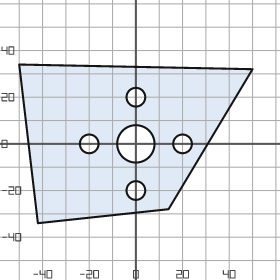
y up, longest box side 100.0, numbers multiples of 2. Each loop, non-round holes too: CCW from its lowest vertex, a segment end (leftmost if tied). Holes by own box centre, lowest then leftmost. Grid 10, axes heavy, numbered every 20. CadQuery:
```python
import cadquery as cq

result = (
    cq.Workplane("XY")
    .moveTo(-42.0, -34.0)
    .lineTo(14.0, -28.0)
    .lineTo(50.0, 32.0)
    .lineTo(-50.0, 34.0)
    .close()
    .moveTo(0.0, -20.0)
    .circle(4.0)
    .moveTo(-20.0, 0.0)
    .circle(4.0)
    .moveTo(0.0, 0.0)
    .circle(8.0)
    .moveTo(20.0, 0.0)
    .circle(4.0)
    .moveTo(0.0, 20.0)
    .circle(4.0)
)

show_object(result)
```